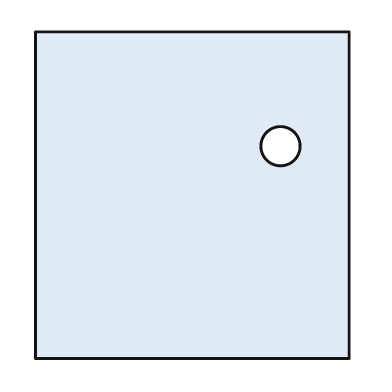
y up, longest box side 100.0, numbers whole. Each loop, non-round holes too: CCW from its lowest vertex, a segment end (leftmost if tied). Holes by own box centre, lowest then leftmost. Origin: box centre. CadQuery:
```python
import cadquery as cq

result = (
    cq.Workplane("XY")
    .moveTo(-48.0, -50.0)
    .lineTo(48.0, -50.0)
    .lineTo(48.0, 50.0)
    .lineTo(-48.0, 50.0)
    .close()
    .moveTo(27.0, 15.0)
    .circle(6.0)
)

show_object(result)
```